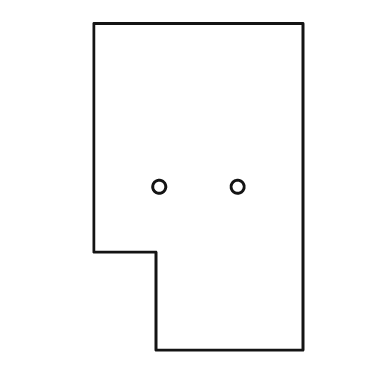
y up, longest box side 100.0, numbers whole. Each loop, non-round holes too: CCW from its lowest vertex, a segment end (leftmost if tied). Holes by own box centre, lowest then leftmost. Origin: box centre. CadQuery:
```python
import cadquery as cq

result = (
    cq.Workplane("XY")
    .moveTo(-13.0, -50.0)
    .lineTo(32.0, -50.0)
    .lineTo(32.0, 50.0)
    .lineTo(-32.0, 50.0)
    .lineTo(-32.0, -20.0)
    .lineTo(-13.0, -20.0)
    .close()
    .moveTo(-12.0, 0.0)
    .circle(2.0)
    .moveTo(12.0, 0.0)
    .circle(2.0)
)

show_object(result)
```